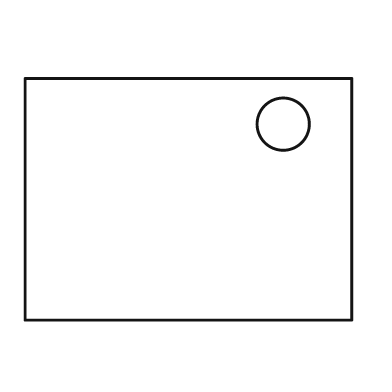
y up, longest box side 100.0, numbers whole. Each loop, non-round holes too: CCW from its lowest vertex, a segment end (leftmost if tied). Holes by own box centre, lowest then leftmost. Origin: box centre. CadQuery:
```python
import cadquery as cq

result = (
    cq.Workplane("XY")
    .moveTo(-50.0, -37.0)
    .lineTo(50.0, -37.0)
    .lineTo(50.0, 37.0)
    .lineTo(-50.0, 37.0)
    .close()
    .moveTo(29.0, 23.0)
    .circle(8.0)
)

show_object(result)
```